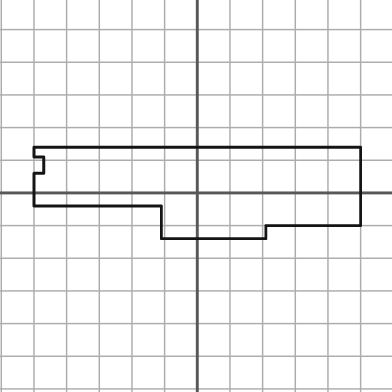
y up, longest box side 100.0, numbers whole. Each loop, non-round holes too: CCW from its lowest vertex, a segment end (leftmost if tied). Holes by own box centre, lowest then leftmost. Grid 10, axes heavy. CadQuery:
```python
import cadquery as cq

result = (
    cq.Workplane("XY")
    .moveTo(-11.0, -14.0)
    .lineTo(21.0, -14.0)
    .lineTo(21.0, -10.0)
    .lineTo(50.0, -10.0)
    .lineTo(50.0, 14.0)
    .lineTo(-50.0, 14.0)
    .lineTo(-50.0, 11.0)
    .lineTo(-47.0, 11.0)
    .lineTo(-47.0, 6.0)
    .lineTo(-50.0, 6.0)
    .lineTo(-50.0, -4.0)
    .lineTo(-11.0, -4.0)
    .close()
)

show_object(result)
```